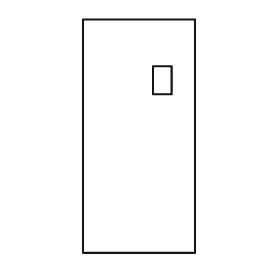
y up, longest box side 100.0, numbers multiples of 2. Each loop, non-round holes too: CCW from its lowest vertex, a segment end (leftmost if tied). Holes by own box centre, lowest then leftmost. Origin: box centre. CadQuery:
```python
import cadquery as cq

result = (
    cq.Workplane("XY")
    .moveTo(-24.0, -50.0)
    .lineTo(24.0, -50.0)
    .lineTo(24.0, 50.0)
    .lineTo(-24.0, 50.0)
    .close()
    .moveTo(6.0, 18.0)
    .lineTo(14.0, 18.0)
    .lineTo(14.0, 30.0)
    .lineTo(6.0, 30.0)
    .close()
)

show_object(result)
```